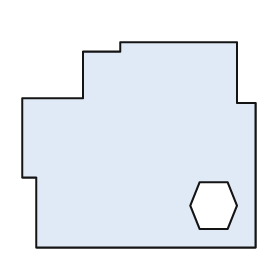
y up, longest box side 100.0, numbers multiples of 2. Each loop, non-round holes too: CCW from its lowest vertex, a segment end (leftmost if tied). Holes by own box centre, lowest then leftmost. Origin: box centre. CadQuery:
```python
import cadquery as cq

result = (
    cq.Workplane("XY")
    .moveTo(-44.0, -44.0)
    .lineTo(50.0, -44.0)
    .lineTo(50.0, 18.0)
    .lineTo(42.0, 18.0)
    .lineTo(42.0, 44.0)
    .lineTo(-8.0, 44.0)
    .lineTo(-8.0, 40.0)
    .lineTo(-24.0, 40.0)
    .lineTo(-24.0, 20.0)
    .lineTo(-50.0, 20.0)
    .lineTo(-50.0, -14.0)
    .lineTo(-44.0, -14.0)
    .close()
    .moveTo(26.0, -36.0)
    .lineTo(38.0, -36.0)
    .lineTo(42.0, -26.0)
    .lineTo(38.0, -16.0)
    .lineTo(26.0, -16.0)
    .lineTo(22.0, -26.0)
    .close()
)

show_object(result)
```